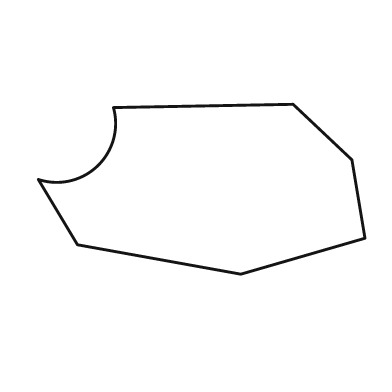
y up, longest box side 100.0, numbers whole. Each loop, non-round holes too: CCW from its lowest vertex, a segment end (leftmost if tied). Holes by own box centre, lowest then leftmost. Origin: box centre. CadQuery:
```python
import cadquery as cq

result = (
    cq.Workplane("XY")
    .moveTo(12.0, -26.0)
    .lineTo(50.0, -15.0)
    .lineTo(46.0, 9.0)
    .lineTo(28.0, 26.0)
    .lineTo(-27.0, 25.0)
    .threePointArc((-32.0, 7.0), (-50.0, 3.0))
    .lineTo(-38.0, -17.0)
    .close()
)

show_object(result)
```